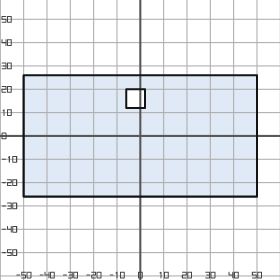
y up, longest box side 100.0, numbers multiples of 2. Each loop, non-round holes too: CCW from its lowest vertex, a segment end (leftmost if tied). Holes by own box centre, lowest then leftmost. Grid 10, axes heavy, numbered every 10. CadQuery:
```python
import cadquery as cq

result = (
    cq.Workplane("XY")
    .moveTo(-50.0, -26.0)
    .lineTo(50.0, -26.0)
    .lineTo(50.0, 26.0)
    .lineTo(-50.0, 26.0)
    .close()
    .moveTo(-6.0, 12.0)
    .lineTo(2.0, 12.0)
    .lineTo(2.0, 20.0)
    .lineTo(-6.0, 20.0)
    .close()
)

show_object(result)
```